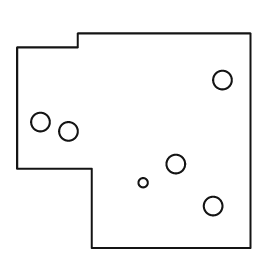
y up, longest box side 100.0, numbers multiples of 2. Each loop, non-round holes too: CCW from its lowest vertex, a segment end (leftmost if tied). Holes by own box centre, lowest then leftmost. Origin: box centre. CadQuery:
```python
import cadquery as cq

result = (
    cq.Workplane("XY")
    .moveTo(-18.0, -46.0)
    .lineTo(50.0, -46.0)
    .lineTo(50.0, 46.0)
    .lineTo(-24.0, 46.0)
    .lineTo(-24.0, 40.0)
    .lineTo(-50.0, 40.0)
    .lineTo(-50.0, -12.0)
    .lineTo(-18.0, -12.0)
    .close()
    .moveTo(34.0, -28.0)
    .circle(4.0)
    .moveTo(4.0, -18.0)
    .circle(2.0)
    .moveTo(18.0, -10.0)
    .circle(4.0)
    .moveTo(-28.0, 4.0)
    .circle(4.0)
    .moveTo(-40.0, 8.0)
    .circle(4.0)
    .moveTo(38.0, 26.0)
    .circle(4.0)
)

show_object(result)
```